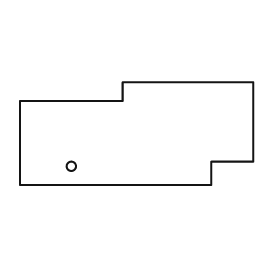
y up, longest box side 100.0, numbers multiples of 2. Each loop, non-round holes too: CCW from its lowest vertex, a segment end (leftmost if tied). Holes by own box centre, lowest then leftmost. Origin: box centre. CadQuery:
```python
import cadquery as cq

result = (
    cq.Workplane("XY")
    .moveTo(-50.0, -22.0)
    .lineTo(32.0, -22.0)
    .lineTo(32.0, -12.0)
    .lineTo(50.0, -12.0)
    .lineTo(50.0, 22.0)
    .lineTo(-6.0, 22.0)
    .lineTo(-6.0, 14.0)
    .lineTo(-50.0, 14.0)
    .close()
    .moveTo(-28.0, -14.0)
    .circle(2.0)
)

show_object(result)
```